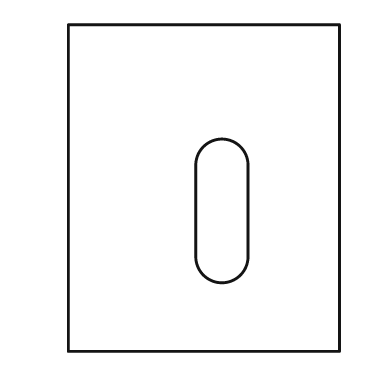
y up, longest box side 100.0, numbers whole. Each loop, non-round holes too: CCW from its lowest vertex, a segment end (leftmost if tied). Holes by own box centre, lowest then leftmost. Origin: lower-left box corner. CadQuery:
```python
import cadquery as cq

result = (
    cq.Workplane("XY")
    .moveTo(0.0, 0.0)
    .lineTo(83.0, 0.0)
    .lineTo(83.0, 100.0)
    .lineTo(0.0, 100.0)
    .close()
    .moveTo(39.0, 29.0)
    .threePointArc((47.0, 21.0), (55.0, 29.0))
    .lineTo(55.0, 57.0)
    .threePointArc((47.0, 65.0), (39.0, 57.0))
    .close()
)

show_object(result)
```